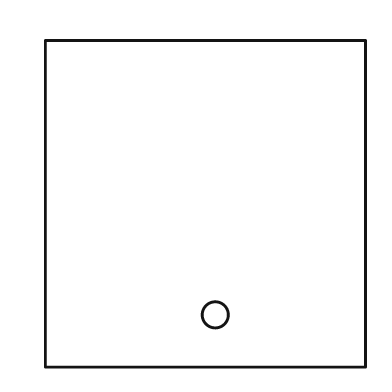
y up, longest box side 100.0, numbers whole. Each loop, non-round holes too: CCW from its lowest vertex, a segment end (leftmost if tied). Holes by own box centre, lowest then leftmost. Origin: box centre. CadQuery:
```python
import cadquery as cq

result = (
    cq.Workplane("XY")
    .moveTo(-49.0, -50.0)
    .lineTo(49.0, -50.0)
    .lineTo(49.0, 50.0)
    .lineTo(-49.0, 50.0)
    .close()
    .moveTo(3.0, -34.0)
    .circle(4.0)
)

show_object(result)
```